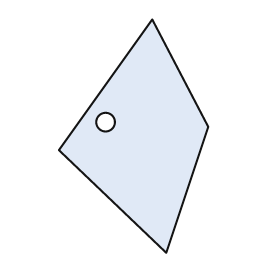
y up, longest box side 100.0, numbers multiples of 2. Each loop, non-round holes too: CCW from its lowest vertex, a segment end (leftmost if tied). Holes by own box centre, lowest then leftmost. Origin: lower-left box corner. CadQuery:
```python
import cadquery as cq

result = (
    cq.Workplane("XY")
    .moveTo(46.0, 0.0)
    .lineTo(64.0, 54.0)
    .lineTo(40.0, 100.0)
    .lineTo(0.0, 44.0)
    .close()
    .moveTo(20.0, 56.0)
    .circle(4.0)
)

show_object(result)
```